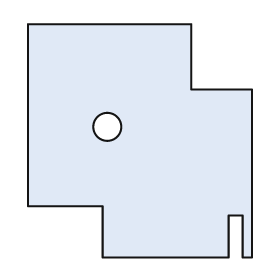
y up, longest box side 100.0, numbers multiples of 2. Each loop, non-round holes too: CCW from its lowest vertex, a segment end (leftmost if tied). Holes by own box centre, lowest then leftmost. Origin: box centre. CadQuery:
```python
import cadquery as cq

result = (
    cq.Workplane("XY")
    .moveTo(-16.0, -50.0)
    .lineTo(38.0, -50.0)
    .lineTo(38.0, -32.0)
    .lineTo(44.0, -32.0)
    .lineTo(44.0, -50.0)
    .lineTo(48.0, -50.0)
    .lineTo(48.0, 22.0)
    .lineTo(22.0, 22.0)
    .lineTo(22.0, 50.0)
    .lineTo(-48.0, 50.0)
    .lineTo(-48.0, -28.0)
    .lineTo(-16.0, -28.0)
    .close()
    .moveTo(-14.0, 6.0)
    .circle(6.0)
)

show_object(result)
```